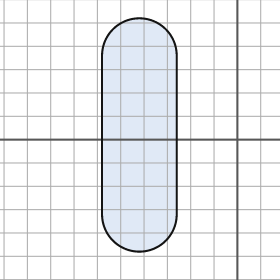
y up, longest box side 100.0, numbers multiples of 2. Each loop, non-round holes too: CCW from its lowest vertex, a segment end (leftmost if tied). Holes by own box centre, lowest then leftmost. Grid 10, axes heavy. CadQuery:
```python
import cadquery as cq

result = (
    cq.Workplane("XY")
    .moveTo(-58.0, -32.0)
    .threePointArc((-42.0, -48.0), (-26.0, -32.0))
    .lineTo(-26.0, 36.0)
    .threePointArc((-42.0, 52.0), (-58.0, 36.0))
    .close()
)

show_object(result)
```